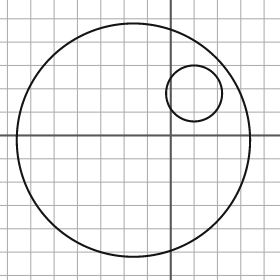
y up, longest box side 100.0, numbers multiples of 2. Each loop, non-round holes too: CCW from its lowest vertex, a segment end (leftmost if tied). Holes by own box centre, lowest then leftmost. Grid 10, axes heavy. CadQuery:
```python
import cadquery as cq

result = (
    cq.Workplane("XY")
    .moveTo(-16.0, -2.0)
    .circle(50.0)
    .moveTo(10.0, 18.0)
    .circle(12.0)
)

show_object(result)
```